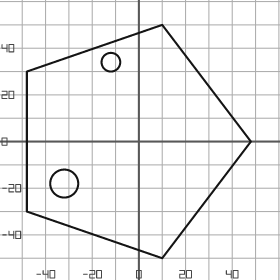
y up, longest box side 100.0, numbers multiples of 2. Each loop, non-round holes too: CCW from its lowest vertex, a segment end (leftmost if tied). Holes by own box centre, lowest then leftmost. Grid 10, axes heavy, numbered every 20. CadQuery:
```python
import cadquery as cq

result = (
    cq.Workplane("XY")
    .moveTo(10.0, -50.0)
    .lineTo(48.0, 0.0)
    .lineTo(10.0, 50.0)
    .lineTo(-48.0, 30.0)
    .lineTo(-48.0, -30.0)
    .close()
    .moveTo(-32.0, -18.0)
    .circle(6.0)
    .moveTo(-12.0, 34.0)
    .circle(4.0)
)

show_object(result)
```